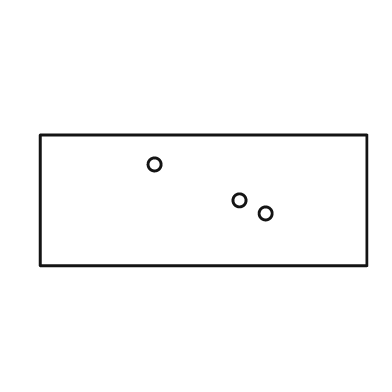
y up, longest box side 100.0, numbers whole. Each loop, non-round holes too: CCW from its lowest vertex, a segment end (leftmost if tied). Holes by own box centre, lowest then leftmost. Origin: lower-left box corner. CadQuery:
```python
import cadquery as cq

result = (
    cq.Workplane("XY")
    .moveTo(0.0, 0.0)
    .lineTo(100.0, 0.0)
    .lineTo(100.0, 40.0)
    .lineTo(0.0, 40.0)
    .close()
    .moveTo(69.0, 16.0)
    .circle(2.0)
    .moveTo(61.0, 20.0)
    .circle(2.0)
    .moveTo(35.0, 31.0)
    .circle(2.0)
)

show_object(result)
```